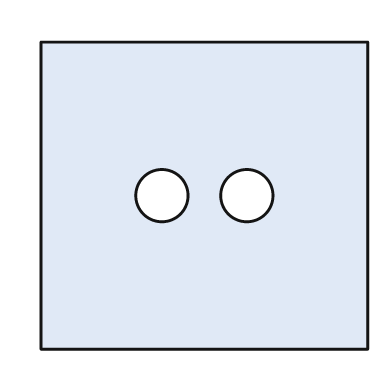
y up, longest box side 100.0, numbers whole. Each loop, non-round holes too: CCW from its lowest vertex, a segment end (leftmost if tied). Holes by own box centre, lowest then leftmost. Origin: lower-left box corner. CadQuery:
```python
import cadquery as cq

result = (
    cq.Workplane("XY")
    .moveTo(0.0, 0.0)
    .lineTo(100.0, 0.0)
    .lineTo(100.0, 94.0)
    .lineTo(0.0, 94.0)
    .close()
    .moveTo(37.0, 47.0)
    .circle(8.0)
    .moveTo(63.0, 47.0)
    .circle(8.0)
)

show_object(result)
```